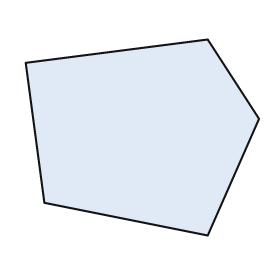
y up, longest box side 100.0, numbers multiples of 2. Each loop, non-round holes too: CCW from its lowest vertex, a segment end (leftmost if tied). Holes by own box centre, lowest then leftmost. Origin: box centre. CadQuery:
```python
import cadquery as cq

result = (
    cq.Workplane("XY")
    .moveTo(28.0, -42.0)
    .lineTo(50.0, 8.0)
    .lineTo(28.0, 42.0)
    .lineTo(-50.0, 32.0)
    .lineTo(-42.0, -28.0)
    .close()
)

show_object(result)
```